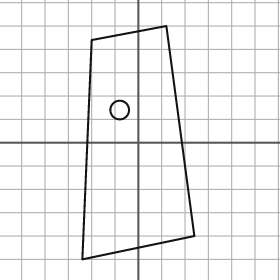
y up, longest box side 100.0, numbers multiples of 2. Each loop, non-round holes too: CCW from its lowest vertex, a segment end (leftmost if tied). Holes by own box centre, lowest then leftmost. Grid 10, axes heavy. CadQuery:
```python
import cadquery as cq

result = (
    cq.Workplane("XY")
    .moveTo(-24.0, -50.0)
    .lineTo(24.0, -40.0)
    .lineTo(12.0, 50.0)
    .lineTo(-20.0, 44.0)
    .close()
    .moveTo(-8.0, 14.0)
    .circle(4.0)
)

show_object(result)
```